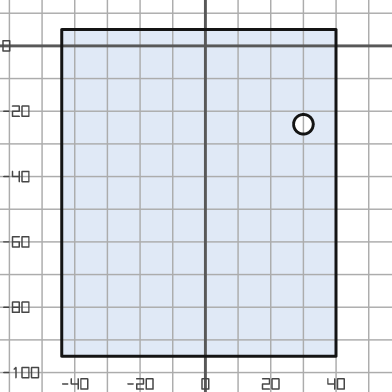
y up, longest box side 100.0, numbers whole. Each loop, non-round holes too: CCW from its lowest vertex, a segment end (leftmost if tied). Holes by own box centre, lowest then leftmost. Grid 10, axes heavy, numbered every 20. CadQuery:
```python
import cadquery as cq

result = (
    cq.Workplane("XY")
    .moveTo(-44.0, -95.0)
    .lineTo(40.0, -95.0)
    .lineTo(40.0, 5.0)
    .lineTo(-44.0, 5.0)
    .close()
    .moveTo(30.0, -24.0)
    .circle(3.0)
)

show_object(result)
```